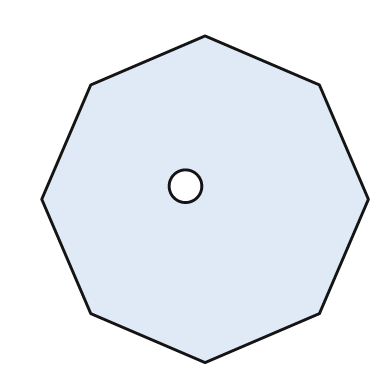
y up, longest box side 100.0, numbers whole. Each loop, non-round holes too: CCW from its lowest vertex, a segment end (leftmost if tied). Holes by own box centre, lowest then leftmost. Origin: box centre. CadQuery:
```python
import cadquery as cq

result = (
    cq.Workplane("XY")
    .moveTo(0.0, -50.0)
    .lineTo(35.0, -35.0)
    .lineTo(50.0, 0.0)
    .lineTo(35.0, 35.0)
    .lineTo(0.0, 50.0)
    .lineTo(-35.0, 35.0)
    .lineTo(-50.0, 0.0)
    .lineTo(-35.0, -35.0)
    .close()
    .moveTo(-6.0, 4.0)
    .circle(5.0)
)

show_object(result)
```